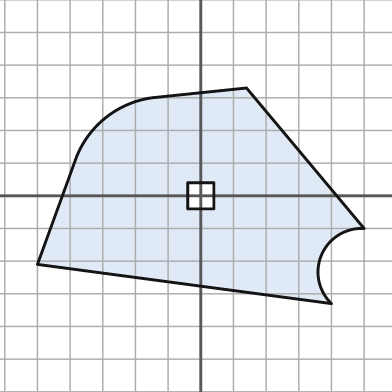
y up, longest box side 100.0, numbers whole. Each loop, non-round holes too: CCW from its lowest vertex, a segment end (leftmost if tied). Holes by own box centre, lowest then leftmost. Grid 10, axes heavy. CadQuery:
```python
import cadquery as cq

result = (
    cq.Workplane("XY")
    .moveTo(40.0, -33.0)
    .threePointArc((37.0, -18.0), (50.0, -10.0))
    .lineTo(14.0, 33.0)
    .lineTo(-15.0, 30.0)
    .threePointArc((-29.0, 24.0), (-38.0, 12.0))
    .lineTo(-50.0, -21.0)
    .close()
    .moveTo(-4.0, -4.0)
    .lineTo(4.0, -4.0)
    .lineTo(4.0, 4.0)
    .lineTo(-4.0, 4.0)
    .close()
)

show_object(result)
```